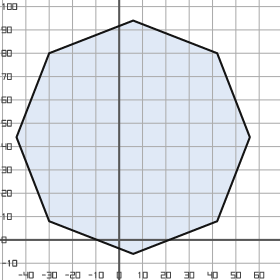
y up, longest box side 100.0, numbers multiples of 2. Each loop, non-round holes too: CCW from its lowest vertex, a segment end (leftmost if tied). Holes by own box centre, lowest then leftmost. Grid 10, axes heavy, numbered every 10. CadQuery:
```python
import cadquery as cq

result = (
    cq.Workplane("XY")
    .moveTo(6.0, -6.0)
    .lineTo(42.0, 8.0)
    .lineTo(56.0, 44.0)
    .lineTo(42.0, 80.0)
    .lineTo(6.0, 94.0)
    .lineTo(-30.0, 80.0)
    .lineTo(-44.0, 44.0)
    .lineTo(-30.0, 8.0)
    .close()
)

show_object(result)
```